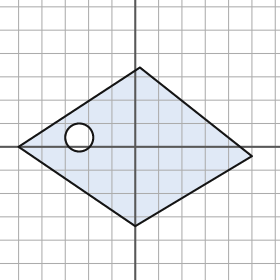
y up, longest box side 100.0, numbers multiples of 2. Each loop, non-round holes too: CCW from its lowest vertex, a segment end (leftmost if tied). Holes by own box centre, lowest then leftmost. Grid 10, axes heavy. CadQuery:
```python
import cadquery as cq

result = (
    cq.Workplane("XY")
    .moveTo(0.0, -34.0)
    .lineTo(50.0, -4.0)
    .lineTo(2.0, 34.0)
    .lineTo(-50.0, 0.0)
    .close()
    .moveTo(-24.0, 4.0)
    .circle(6.0)
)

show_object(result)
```